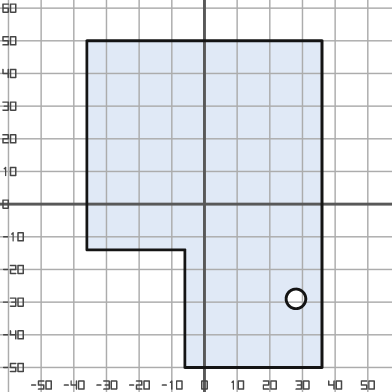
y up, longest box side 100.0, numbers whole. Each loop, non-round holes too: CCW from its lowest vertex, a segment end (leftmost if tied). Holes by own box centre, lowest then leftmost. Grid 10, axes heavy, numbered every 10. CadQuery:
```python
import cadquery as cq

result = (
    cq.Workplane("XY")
    .moveTo(-6.0, -50.0)
    .lineTo(36.0, -50.0)
    .lineTo(36.0, 50.0)
    .lineTo(-36.0, 50.0)
    .lineTo(-36.0, -14.0)
    .lineTo(-6.0, -14.0)
    .close()
    .moveTo(28.0, -29.0)
    .circle(3.0)
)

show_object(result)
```